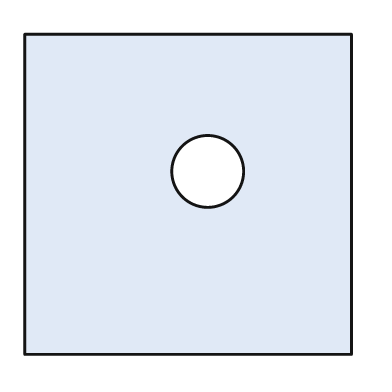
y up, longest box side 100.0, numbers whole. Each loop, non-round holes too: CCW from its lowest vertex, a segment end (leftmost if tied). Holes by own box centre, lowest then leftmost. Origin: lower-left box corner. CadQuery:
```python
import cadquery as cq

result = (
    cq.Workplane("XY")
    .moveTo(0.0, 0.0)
    .lineTo(100.0, 0.0)
    .lineTo(100.0, 98.0)
    .lineTo(0.0, 98.0)
    .close()
    .moveTo(56.0, 56.0)
    .circle(11.0)
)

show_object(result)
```